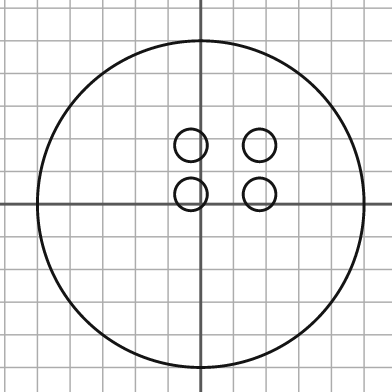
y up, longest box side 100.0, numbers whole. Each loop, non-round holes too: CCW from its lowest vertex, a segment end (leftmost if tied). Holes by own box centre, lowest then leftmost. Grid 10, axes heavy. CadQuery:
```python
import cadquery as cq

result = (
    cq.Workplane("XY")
    .moveTo(0.0, 0.0)
    .circle(50.0)
    .moveTo(-3.0, 3.0)
    .circle(5.0)
    .moveTo(18.0, 3.0)
    .circle(5.0)
    .moveTo(-3.0, 18.0)
    .circle(5.0)
    .moveTo(18.0, 18.0)
    .circle(5.0)
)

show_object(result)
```